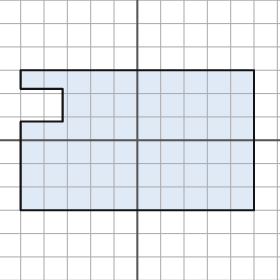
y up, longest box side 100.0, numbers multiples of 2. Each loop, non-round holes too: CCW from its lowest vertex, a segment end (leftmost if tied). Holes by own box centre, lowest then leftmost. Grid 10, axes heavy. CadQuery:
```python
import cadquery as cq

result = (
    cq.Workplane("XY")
    .moveTo(-50.0, -30.0)
    .lineTo(50.0, -30.0)
    .lineTo(50.0, 30.0)
    .lineTo(-50.0, 30.0)
    .lineTo(-50.0, 22.0)
    .lineTo(-32.0, 22.0)
    .lineTo(-32.0, 8.0)
    .lineTo(-50.0, 8.0)
    .close()
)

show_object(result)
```